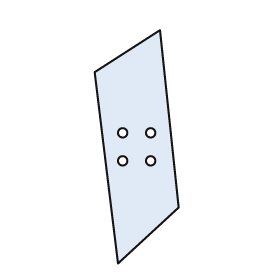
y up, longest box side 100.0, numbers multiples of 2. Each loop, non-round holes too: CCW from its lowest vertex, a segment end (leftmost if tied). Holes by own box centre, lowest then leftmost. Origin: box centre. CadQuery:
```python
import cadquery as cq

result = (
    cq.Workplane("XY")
    .moveTo(-8.0, -50.0)
    .lineTo(18.0, -26.0)
    .lineTo(10.0, 50.0)
    .lineTo(-18.0, 32.0)
    .close()
    .moveTo(-6.0, -6.0)
    .circle(2.0)
    .moveTo(6.0, -6.0)
    .circle(2.0)
    .moveTo(-6.0, 6.0)
    .circle(2.0)
    .moveTo(6.0, 6.0)
    .circle(2.0)
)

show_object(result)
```